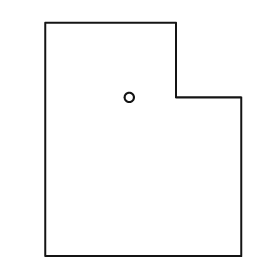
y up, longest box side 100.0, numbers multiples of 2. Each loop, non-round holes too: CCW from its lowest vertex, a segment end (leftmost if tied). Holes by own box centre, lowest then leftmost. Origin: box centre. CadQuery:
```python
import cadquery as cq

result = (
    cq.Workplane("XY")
    .moveTo(-42.0, -50.0)
    .lineTo(42.0, -50.0)
    .lineTo(42.0, 18.0)
    .lineTo(14.0, 18.0)
    .lineTo(14.0, 50.0)
    .lineTo(-42.0, 50.0)
    .close()
    .moveTo(-6.0, 18.0)
    .circle(2.0)
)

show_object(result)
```